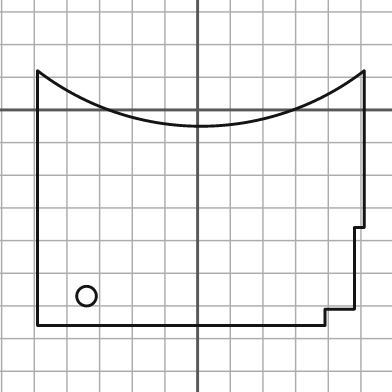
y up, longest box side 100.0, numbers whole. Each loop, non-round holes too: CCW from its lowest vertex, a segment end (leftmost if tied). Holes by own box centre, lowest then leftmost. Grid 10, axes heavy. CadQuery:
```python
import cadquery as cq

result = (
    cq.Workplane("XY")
    .moveTo(-49.0, -66.0)
    .lineTo(39.0, -66.0)
    .lineTo(39.0, -61.0)
    .lineTo(48.0, -61.0)
    .lineTo(48.0, -36.0)
    .lineTo(51.0, -36.0)
    .lineTo(51.0, 12.0)
    .threePointArc((1.0, -5.0), (-49.0, 12.0))
    .close()
    .moveTo(-34.0, -57.0)
    .circle(3.0)
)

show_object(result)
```